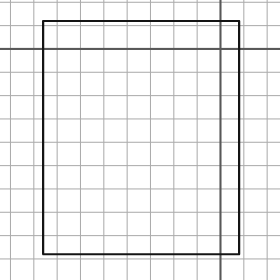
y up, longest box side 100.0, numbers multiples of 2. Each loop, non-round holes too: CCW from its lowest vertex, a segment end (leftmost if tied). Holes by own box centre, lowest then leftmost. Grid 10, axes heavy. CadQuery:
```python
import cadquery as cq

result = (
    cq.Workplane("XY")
    .moveTo(-76.0, -88.0)
    .lineTo(8.0, -88.0)
    .lineTo(8.0, 12.0)
    .lineTo(-76.0, 12.0)
    .close()
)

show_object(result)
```